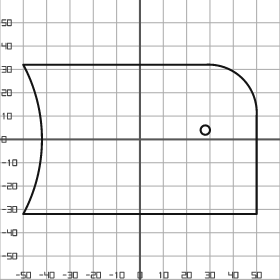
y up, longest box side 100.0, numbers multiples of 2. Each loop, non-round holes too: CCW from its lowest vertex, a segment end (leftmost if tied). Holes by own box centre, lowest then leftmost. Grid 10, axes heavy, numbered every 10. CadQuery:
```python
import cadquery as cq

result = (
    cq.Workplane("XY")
    .moveTo(-50.0, -32.0)
    .lineTo(50.0, -32.0)
    .lineTo(50.0, 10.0)
    .threePointArc((44.0, 26.0), (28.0, 32.0))
    .lineTo(-50.0, 32.0)
    .threePointArc((-42.0, 0.0), (-50.0, -32.0))
    .close()
    .moveTo(28.0, 4.0)
    .circle(2.0)
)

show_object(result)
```